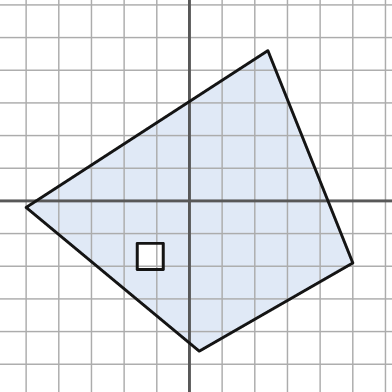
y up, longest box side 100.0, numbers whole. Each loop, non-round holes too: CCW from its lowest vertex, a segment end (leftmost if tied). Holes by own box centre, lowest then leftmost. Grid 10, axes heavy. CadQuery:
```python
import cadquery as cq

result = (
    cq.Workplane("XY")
    .moveTo(3.0, -46.0)
    .lineTo(50.0, -19.0)
    .lineTo(24.0, 46.0)
    .lineTo(-50.0, -2.0)
    .close()
    .moveTo(-16.0, -21.0)
    .lineTo(-8.0, -21.0)
    .lineTo(-8.0, -13.0)
    .lineTo(-16.0, -13.0)
    .close()
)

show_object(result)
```